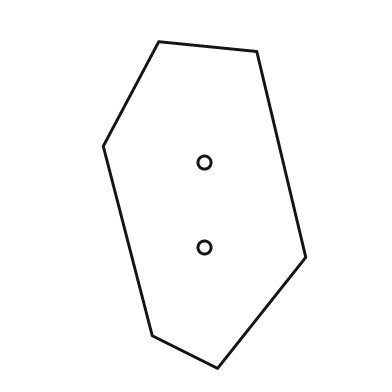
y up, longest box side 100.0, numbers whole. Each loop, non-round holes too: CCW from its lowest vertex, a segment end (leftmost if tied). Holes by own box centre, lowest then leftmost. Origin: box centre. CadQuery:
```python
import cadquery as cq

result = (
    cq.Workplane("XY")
    .moveTo(4.0, -50.0)
    .lineTo(31.0, -16.0)
    .lineTo(16.0, 47.0)
    .lineTo(-14.0, 50.0)
    .lineTo(-31.0, 18.0)
    .lineTo(-16.0, -40.0)
    .close()
    .moveTo(0.0, -13.0)
    .circle(2.0)
    .moveTo(0.0, 13.0)
    .circle(2.0)
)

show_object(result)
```